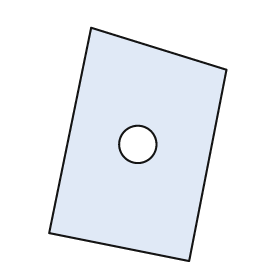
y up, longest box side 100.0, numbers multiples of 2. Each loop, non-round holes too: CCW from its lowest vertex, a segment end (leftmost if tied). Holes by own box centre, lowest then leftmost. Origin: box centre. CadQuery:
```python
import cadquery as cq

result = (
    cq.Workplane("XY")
    .moveTo(22.0, -50.0)
    .lineTo(38.0, 32.0)
    .lineTo(-20.0, 50.0)
    .lineTo(-38.0, -38.0)
    .close()
    .moveTo(0.0, 0.0)
    .circle(8.0)
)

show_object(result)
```